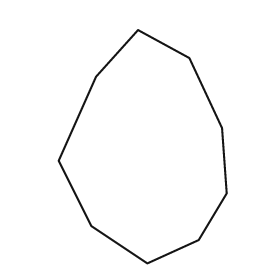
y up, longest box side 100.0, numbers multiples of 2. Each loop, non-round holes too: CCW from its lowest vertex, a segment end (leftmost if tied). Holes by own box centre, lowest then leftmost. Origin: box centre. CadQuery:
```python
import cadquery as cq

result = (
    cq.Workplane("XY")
    .moveTo(2.0, -50.0)
    .lineTo(24.0, -40.0)
    .lineTo(36.0, -20.0)
    .lineTo(34.0, 8.0)
    .lineTo(20.0, 38.0)
    .lineTo(-2.0, 50.0)
    .lineTo(-20.0, 30.0)
    .lineTo(-36.0, -6.0)
    .lineTo(-22.0, -34.0)
    .close()
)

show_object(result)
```